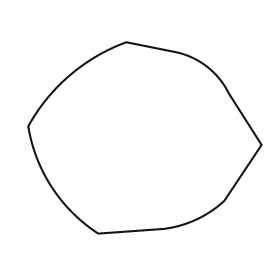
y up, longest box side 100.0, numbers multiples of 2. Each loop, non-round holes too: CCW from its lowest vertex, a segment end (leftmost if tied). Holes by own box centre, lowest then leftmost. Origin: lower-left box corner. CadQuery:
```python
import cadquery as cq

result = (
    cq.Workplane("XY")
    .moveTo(30.0, 0.0)
    .lineTo(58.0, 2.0)
    .threePointArc((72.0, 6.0), (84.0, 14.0))
    .lineTo(100.0, 38.0)
    .lineTo(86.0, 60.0)
    .threePointArc((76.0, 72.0), (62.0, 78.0))
    .lineTo(42.0, 82.0)
    .threePointArc((18.0, 68.0), (0.0, 46.0))
    .threePointArc((10.0, 20.0), (30.0, 0.0))
    .close()
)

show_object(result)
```